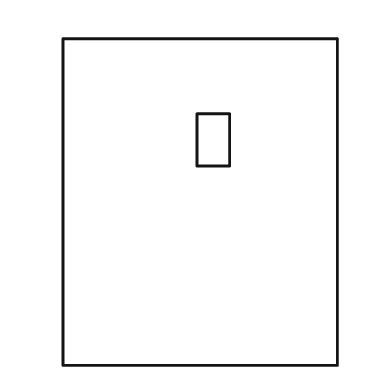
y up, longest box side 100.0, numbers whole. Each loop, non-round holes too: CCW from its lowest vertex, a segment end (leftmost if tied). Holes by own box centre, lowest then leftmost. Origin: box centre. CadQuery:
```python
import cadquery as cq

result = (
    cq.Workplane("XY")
    .moveTo(-42.0, -50.0)
    .lineTo(42.0, -50.0)
    .lineTo(42.0, 50.0)
    .lineTo(-42.0, 50.0)
    .close()
    .moveTo(-1.0, 11.0)
    .lineTo(9.0, 11.0)
    .lineTo(9.0, 27.0)
    .lineTo(-1.0, 27.0)
    .close()
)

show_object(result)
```